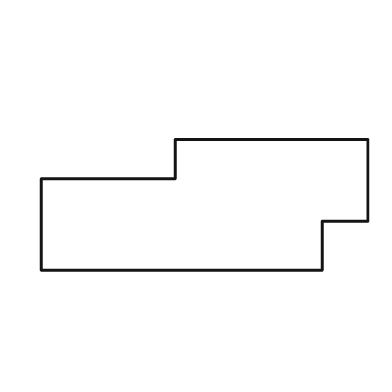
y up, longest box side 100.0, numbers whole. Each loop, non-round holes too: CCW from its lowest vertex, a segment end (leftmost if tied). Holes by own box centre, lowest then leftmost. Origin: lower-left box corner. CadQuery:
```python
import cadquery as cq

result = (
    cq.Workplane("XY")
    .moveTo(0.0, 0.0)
    .lineTo(86.0, 0.0)
    .lineTo(86.0, 15.0)
    .lineTo(100.0, 15.0)
    .lineTo(100.0, 40.0)
    .lineTo(41.0, 40.0)
    .lineTo(41.0, 28.0)
    .lineTo(0.0, 28.0)
    .close()
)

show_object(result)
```